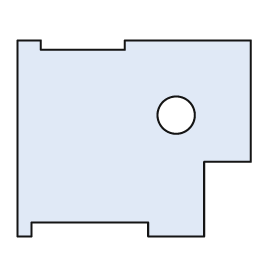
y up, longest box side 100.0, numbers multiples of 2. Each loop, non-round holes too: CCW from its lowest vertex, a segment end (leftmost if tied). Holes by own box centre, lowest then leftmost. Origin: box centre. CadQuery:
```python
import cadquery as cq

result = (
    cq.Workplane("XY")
    .moveTo(-50.0, -42.0)
    .lineTo(-44.0, -42.0)
    .lineTo(-44.0, -36.0)
    .lineTo(6.0, -36.0)
    .lineTo(6.0, -42.0)
    .lineTo(30.0, -42.0)
    .lineTo(30.0, -10.0)
    .lineTo(50.0, -10.0)
    .lineTo(50.0, 42.0)
    .lineTo(-4.0, 42.0)
    .lineTo(-4.0, 38.0)
    .lineTo(-40.0, 38.0)
    .lineTo(-40.0, 42.0)
    .lineTo(-50.0, 42.0)
    .close()
    .moveTo(18.0, 10.0)
    .circle(8.0)
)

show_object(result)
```